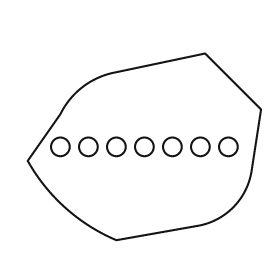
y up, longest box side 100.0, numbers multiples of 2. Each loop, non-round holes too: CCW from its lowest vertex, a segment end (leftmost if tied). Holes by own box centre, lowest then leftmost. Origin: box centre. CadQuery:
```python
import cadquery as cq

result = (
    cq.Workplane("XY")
    .moveTo(-12.0, -40.0)
    .lineTo(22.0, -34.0)
    .threePointArc((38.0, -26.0), (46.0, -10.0))
    .lineTo(50.0, 16.0)
    .lineTo(26.0, 40.0)
    .lineTo(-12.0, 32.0)
    .threePointArc((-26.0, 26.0), (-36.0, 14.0))
    .lineTo(-50.0, -6.0)
    .threePointArc((-34.0, -26.0), (-12.0, -40.0))
    .close()
    .moveTo(-36.0, 0.0)
    .circle(4.0)
    .moveTo(-24.0, 0.0)
    .circle(4.0)
    .moveTo(-12.0, 0.0)
    .circle(4.0)
    .moveTo(0.0, 0.0)
    .circle(4.0)
    .moveTo(12.0, 0.0)
    .circle(4.0)
    .moveTo(24.0, 0.0)
    .circle(4.0)
    .moveTo(36.0, 0.0)
    .circle(4.0)
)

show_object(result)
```